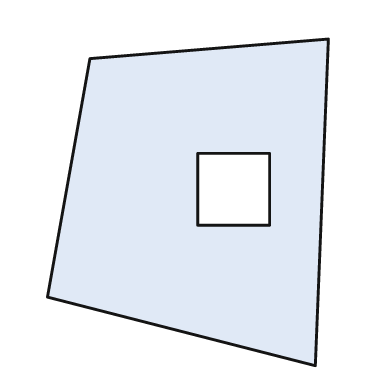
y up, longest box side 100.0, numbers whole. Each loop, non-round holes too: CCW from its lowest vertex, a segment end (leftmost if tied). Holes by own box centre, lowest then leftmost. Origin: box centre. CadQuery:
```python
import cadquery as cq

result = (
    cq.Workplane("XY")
    .moveTo(39.0, -50.0)
    .lineTo(43.0, 50.0)
    .lineTo(-30.0, 44.0)
    .lineTo(-43.0, -29.0)
    .close()
    .moveTo(3.0, -7.0)
    .lineTo(25.0, -7.0)
    .lineTo(25.0, 15.0)
    .lineTo(3.0, 15.0)
    .close()
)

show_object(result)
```